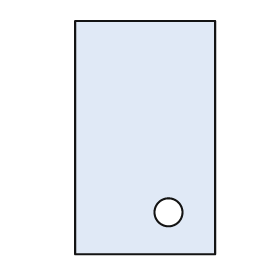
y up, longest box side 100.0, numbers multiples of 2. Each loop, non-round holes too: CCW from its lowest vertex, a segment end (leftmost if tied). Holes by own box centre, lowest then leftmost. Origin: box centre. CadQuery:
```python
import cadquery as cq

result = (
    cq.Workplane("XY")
    .moveTo(-30.0, -50.0)
    .lineTo(30.0, -50.0)
    .lineTo(30.0, 50.0)
    .lineTo(-30.0, 50.0)
    .close()
    .moveTo(10.0, -32.0)
    .circle(6.0)
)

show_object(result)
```